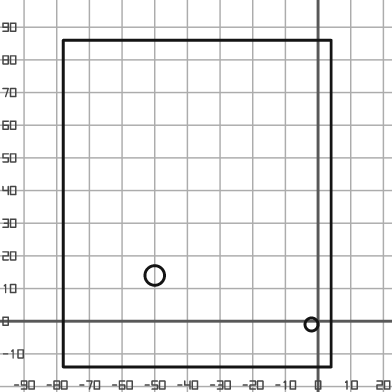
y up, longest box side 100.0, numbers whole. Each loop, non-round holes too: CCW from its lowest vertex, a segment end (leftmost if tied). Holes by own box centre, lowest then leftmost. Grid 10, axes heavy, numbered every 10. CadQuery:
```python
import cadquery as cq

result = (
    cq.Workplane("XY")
    .moveTo(-78.0, -14.0)
    .lineTo(4.0, -14.0)
    .lineTo(4.0, 86.0)
    .lineTo(-78.0, 86.0)
    .close()
    .moveTo(-2.0, -1.0)
    .circle(2.0)
    .moveTo(-50.0, 14.0)
    .circle(3.0)
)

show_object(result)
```